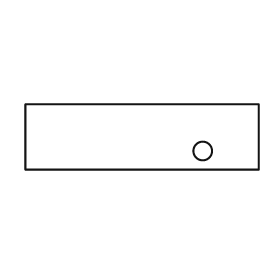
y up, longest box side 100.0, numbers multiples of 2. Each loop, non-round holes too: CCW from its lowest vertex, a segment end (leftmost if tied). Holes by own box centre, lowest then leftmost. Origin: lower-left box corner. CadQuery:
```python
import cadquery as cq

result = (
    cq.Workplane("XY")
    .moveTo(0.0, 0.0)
    .lineTo(100.0, 0.0)
    .lineTo(100.0, 28.0)
    .lineTo(0.0, 28.0)
    .close()
    .moveTo(76.0, 8.0)
    .circle(4.0)
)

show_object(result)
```